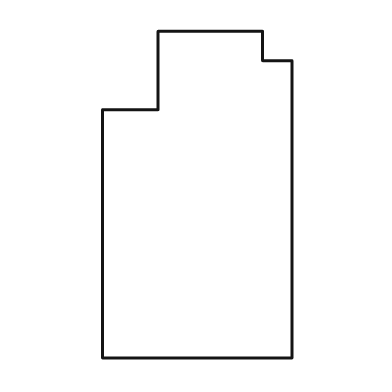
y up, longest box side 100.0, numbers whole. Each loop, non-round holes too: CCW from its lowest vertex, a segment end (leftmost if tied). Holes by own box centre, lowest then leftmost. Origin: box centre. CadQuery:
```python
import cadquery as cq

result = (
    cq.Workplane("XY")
    .moveTo(-29.0, -50.0)
    .lineTo(29.0, -50.0)
    .lineTo(29.0, 41.0)
    .lineTo(20.0, 41.0)
    .lineTo(20.0, 50.0)
    .lineTo(-12.0, 50.0)
    .lineTo(-12.0, 26.0)
    .lineTo(-29.0, 26.0)
    .close()
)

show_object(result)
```